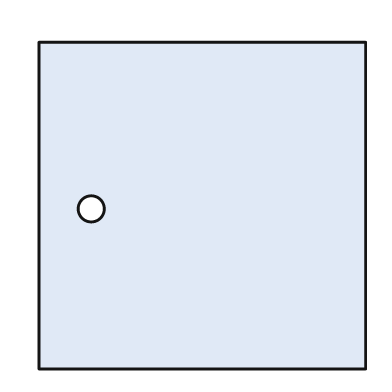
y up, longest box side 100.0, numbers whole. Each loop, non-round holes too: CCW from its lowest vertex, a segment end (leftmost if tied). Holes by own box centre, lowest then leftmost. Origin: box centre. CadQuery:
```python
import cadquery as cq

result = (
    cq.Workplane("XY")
    .moveTo(-50.0, -50.0)
    .lineTo(50.0, -50.0)
    .lineTo(50.0, 50.0)
    .lineTo(-50.0, 50.0)
    .close()
    .moveTo(-34.0, -1.0)
    .circle(4.0)
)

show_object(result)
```